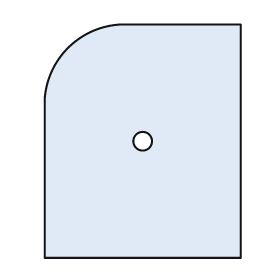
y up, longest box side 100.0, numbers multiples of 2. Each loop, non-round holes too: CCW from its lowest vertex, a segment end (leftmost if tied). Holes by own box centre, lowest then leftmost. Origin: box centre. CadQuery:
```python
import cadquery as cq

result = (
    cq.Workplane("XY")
    .moveTo(-42.0, -50.0)
    .lineTo(42.0, -50.0)
    .lineTo(42.0, 50.0)
    .lineTo(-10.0, 50.0)
    .threePointArc((-32.0, 40.0), (-42.0, 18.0))
    .close()
    .moveTo(0.0, 0.0)
    .circle(4.0)
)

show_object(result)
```